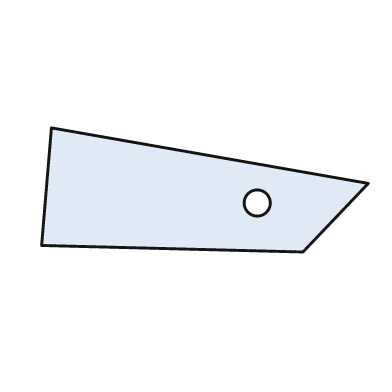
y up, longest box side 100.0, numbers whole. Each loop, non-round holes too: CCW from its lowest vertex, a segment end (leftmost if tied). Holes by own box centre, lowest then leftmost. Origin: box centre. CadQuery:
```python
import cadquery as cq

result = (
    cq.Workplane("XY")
    .moveTo(30.0, -19.0)
    .lineTo(50.0, 2.0)
    .lineTo(-47.0, 19.0)
    .lineTo(-50.0, -17.0)
    .close()
    .moveTo(16.0, -4.0)
    .circle(4.0)
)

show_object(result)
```